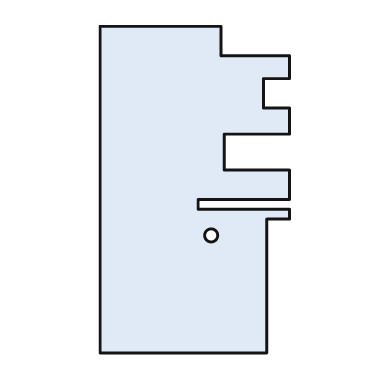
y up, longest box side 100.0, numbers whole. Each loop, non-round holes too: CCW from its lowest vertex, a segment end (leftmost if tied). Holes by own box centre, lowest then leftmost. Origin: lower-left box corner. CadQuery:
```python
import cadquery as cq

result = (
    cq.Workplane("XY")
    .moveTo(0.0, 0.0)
    .lineTo(51.0, 0.0)
    .lineTo(51.0, 41.0)
    .lineTo(58.0, 41.0)
    .lineTo(58.0, 44.0)
    .lineTo(30.0, 44.0)
    .lineTo(30.0, 47.0)
    .lineTo(58.0, 47.0)
    .lineTo(58.0, 56.0)
    .lineTo(38.0, 56.0)
    .lineTo(38.0, 67.0)
    .lineTo(58.0, 67.0)
    .lineTo(58.0, 75.0)
    .lineTo(50.0, 75.0)
    .lineTo(50.0, 84.0)
    .lineTo(58.0, 84.0)
    .lineTo(58.0, 91.0)
    .lineTo(37.0, 91.0)
    .lineTo(37.0, 100.0)
    .lineTo(0.0, 100.0)
    .close()
    .moveTo(34.0, 36.0)
    .circle(2.0)
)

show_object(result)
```